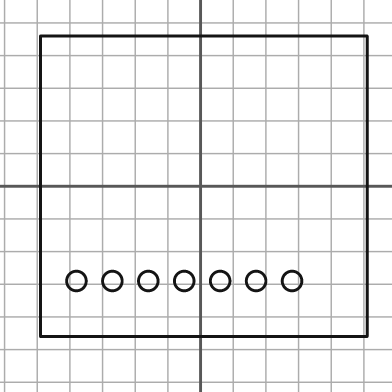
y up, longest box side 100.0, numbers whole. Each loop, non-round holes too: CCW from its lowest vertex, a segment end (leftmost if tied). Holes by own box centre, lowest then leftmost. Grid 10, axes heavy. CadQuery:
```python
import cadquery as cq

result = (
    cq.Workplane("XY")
    .moveTo(-49.0, -46.0)
    .lineTo(51.0, -46.0)
    .lineTo(51.0, 46.0)
    .lineTo(-49.0, 46.0)
    .close()
    .moveTo(-38.0, -29.0)
    .circle(3.0)
    .moveTo(-27.0, -29.0)
    .circle(3.0)
    .moveTo(-16.0, -29.0)
    .circle(3.0)
    .moveTo(-5.0, -29.0)
    .circle(3.0)
    .moveTo(6.0, -29.0)
    .circle(3.0)
    .moveTo(17.0, -29.0)
    .circle(3.0)
    .moveTo(28.0, -29.0)
    .circle(3.0)
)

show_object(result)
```